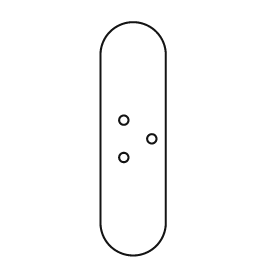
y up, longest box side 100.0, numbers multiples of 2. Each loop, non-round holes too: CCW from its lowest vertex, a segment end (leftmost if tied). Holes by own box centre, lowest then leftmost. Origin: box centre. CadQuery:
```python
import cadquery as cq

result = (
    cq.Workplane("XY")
    .moveTo(-14.0, -36.0)
    .threePointArc((0.0, -50.0), (14.0, -36.0))
    .lineTo(14.0, 36.0)
    .threePointArc((0.0, 50.0), (-14.0, 36.0))
    .close()
    .moveTo(-4.0, -8.0)
    .circle(2.0)
    .moveTo(8.0, 0.0)
    .circle(2.0)
    .moveTo(-4.0, 8.0)
    .circle(2.0)
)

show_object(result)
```